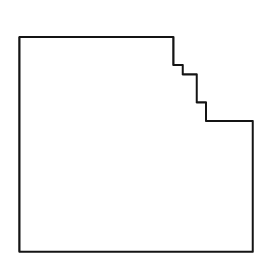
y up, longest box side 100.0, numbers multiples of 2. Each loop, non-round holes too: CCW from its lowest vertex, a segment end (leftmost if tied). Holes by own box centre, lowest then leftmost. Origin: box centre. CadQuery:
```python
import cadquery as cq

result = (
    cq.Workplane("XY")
    .moveTo(-50.0, -46.0)
    .lineTo(50.0, -46.0)
    .lineTo(50.0, 10.0)
    .lineTo(30.0, 10.0)
    .lineTo(30.0, 18.0)
    .lineTo(26.0, 18.0)
    .lineTo(26.0, 30.0)
    .lineTo(20.0, 30.0)
    .lineTo(20.0, 34.0)
    .lineTo(16.0, 34.0)
    .lineTo(16.0, 46.0)
    .lineTo(-50.0, 46.0)
    .close()
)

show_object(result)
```